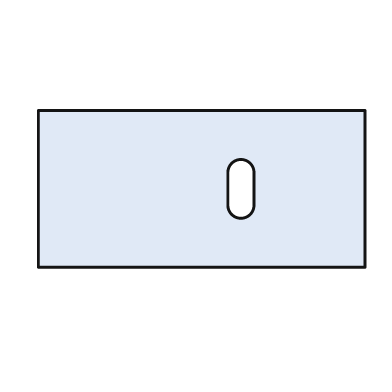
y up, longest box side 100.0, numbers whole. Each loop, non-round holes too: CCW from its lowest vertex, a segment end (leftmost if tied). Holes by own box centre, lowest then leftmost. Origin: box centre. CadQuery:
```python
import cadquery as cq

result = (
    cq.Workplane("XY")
    .moveTo(-50.0, -24.0)
    .lineTo(50.0, -24.0)
    .lineTo(50.0, 24.0)
    .lineTo(-50.0, 24.0)
    .close()
    .moveTo(8.0, -5.0)
    .threePointArc((12.0, -9.0), (16.0, -5.0))
    .lineTo(16.0, 5.0)
    .threePointArc((12.0, 9.0), (8.0, 5.0))
    .close()
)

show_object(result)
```